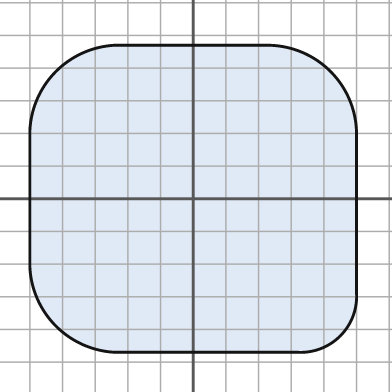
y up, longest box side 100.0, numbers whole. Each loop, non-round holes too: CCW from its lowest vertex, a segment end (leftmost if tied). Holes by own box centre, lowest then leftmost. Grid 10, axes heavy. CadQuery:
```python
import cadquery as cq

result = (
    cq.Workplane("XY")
    .moveTo(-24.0, -47.0)
    .lineTo(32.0, -47.0)
    .threePointArc((45.0, -42.0), (50.0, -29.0))
    .lineTo(50.0, 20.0)
    .threePointArc((42.0, 39.0), (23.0, 47.0))
    .lineTo(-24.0, 47.0)
    .threePointArc((-42.0, 39.0), (-50.0, 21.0))
    .lineTo(-50.0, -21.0)
    .threePointArc((-42.0, -39.0), (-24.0, -47.0))
    .close()
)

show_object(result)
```